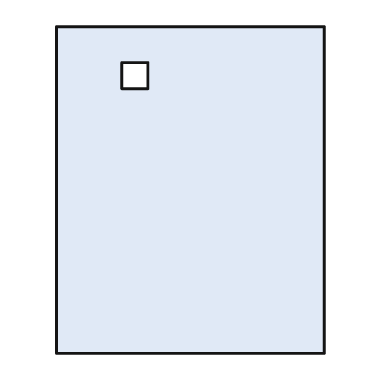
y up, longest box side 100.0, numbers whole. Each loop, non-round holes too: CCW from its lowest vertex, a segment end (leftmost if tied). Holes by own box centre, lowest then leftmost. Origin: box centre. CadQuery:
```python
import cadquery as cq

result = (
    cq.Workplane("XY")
    .moveTo(-41.0, -50.0)
    .lineTo(41.0, -50.0)
    .lineTo(41.0, 50.0)
    .lineTo(-41.0, 50.0)
    .close()
    .moveTo(-21.0, 31.0)
    .lineTo(-13.0, 31.0)
    .lineTo(-13.0, 39.0)
    .lineTo(-21.0, 39.0)
    .close()
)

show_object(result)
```